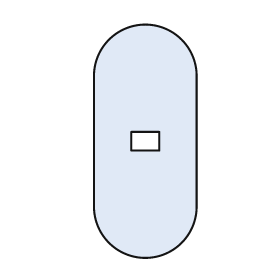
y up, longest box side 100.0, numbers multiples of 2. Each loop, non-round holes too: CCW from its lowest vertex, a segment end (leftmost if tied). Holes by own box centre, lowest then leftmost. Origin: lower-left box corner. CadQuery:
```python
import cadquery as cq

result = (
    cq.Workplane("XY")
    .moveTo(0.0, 22.0)
    .threePointArc((22.0, 0.0), (44.0, 22.0))
    .lineTo(44.0, 78.0)
    .threePointArc((22.0, 100.0), (0.0, 78.0))
    .close()
    .moveTo(16.0, 46.0)
    .lineTo(28.0, 46.0)
    .lineTo(28.0, 54.0)
    .lineTo(16.0, 54.0)
    .close()
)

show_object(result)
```